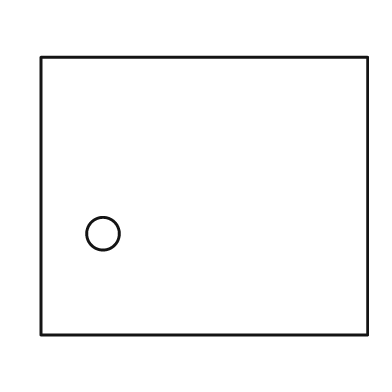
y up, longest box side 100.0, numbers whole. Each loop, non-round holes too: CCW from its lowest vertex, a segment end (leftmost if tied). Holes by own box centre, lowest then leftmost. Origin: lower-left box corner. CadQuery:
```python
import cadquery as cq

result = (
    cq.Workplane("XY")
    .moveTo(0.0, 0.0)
    .lineTo(100.0, 0.0)
    .lineTo(100.0, 85.0)
    .lineTo(0.0, 85.0)
    .close()
    .moveTo(19.0, 31.0)
    .circle(5.0)
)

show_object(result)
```